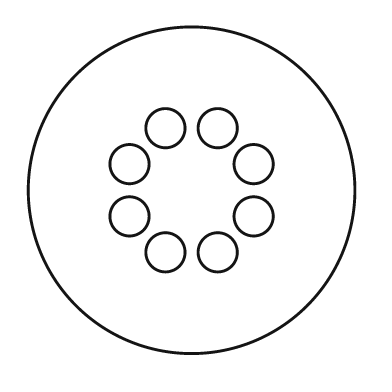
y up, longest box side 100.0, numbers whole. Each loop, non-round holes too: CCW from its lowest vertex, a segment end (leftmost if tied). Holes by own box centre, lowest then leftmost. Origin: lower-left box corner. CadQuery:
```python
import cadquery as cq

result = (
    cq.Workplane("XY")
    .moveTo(50.0, 50.0)
    .circle(50.0)
    .moveTo(42.0, 31.0)
    .circle(6.0)
    .moveTo(58.0, 31.0)
    .circle(6.0)
    .moveTo(31.0, 42.0)
    .circle(6.0)
    .moveTo(69.0, 42.0)
    .circle(6.0)
    .moveTo(31.0, 58.0)
    .circle(6.0)
    .moveTo(69.0, 58.0)
    .circle(6.0)
    .moveTo(42.0, 69.0)
    .circle(6.0)
    .moveTo(58.0, 69.0)
    .circle(6.0)
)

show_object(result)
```